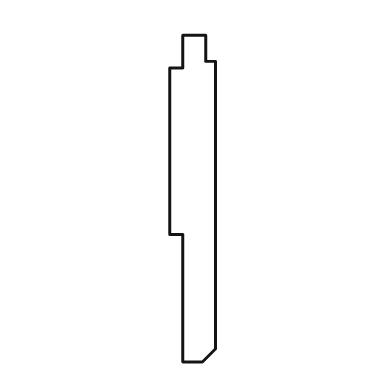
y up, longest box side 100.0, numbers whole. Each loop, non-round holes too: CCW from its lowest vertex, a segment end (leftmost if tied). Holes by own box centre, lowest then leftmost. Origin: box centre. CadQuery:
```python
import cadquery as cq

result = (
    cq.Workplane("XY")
    .moveTo(-3.0, -50.0)
    .lineTo(3.0, -50.0)
    .lineTo(7.0, -46.0)
    .lineTo(7.0, 42.0)
    .lineTo(4.0, 42.0)
    .lineTo(4.0, 50.0)
    .lineTo(-3.0, 50.0)
    .lineTo(-3.0, 40.0)
    .lineTo(-7.0, 40.0)
    .lineTo(-7.0, -11.0)
    .lineTo(-3.0, -11.0)
    .close()
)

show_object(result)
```